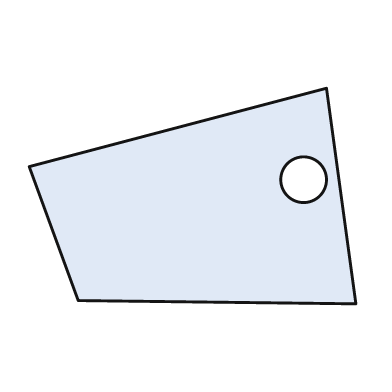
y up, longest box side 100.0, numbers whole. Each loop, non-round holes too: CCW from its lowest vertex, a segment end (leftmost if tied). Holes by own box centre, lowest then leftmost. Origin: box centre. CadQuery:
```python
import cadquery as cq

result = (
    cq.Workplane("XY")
    .moveTo(50.0, -33.0)
    .lineTo(41.0, 33.0)
    .lineTo(-50.0, 9.0)
    .lineTo(-35.0, -32.0)
    .close()
    .moveTo(34.0, 5.0)
    .circle(7.0)
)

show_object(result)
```